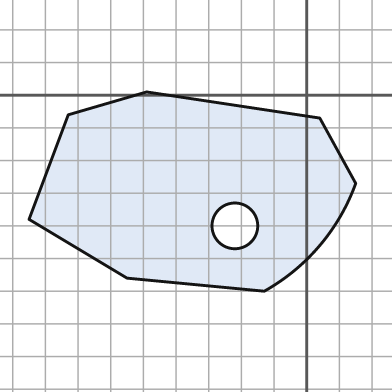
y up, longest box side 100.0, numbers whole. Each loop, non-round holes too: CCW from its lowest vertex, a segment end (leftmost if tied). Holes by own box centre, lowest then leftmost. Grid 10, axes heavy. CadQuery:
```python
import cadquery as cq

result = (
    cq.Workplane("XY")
    .moveTo(-13.0, -60.0)
    .threePointArc((4.0, -46.0), (15.0, -27.0))
    .lineTo(4.0, -7.0)
    .lineTo(-49.0, 1.0)
    .lineTo(-73.0, -6.0)
    .lineTo(-85.0, -38.0)
    .lineTo(-55.0, -56.0)
    .close()
    .moveTo(-22.0, -40.0)
    .circle(7.0)
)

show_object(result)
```